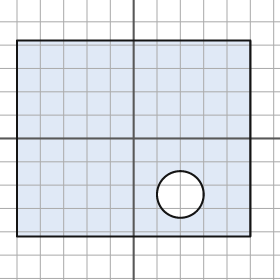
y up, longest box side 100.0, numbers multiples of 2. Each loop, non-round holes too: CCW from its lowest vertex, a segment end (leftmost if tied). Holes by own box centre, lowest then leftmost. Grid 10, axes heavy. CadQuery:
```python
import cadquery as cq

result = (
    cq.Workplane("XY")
    .moveTo(-50.0, -42.0)
    .lineTo(50.0, -42.0)
    .lineTo(50.0, 42.0)
    .lineTo(-50.0, 42.0)
    .close()
    .moveTo(20.0, -24.0)
    .circle(10.0)
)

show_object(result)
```